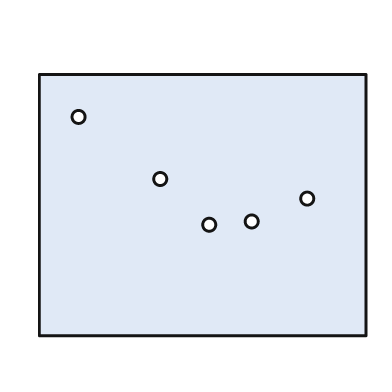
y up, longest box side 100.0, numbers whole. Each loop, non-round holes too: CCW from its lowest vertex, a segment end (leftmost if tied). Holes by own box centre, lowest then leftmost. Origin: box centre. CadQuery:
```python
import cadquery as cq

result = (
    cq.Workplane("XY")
    .moveTo(-50.0, -40.0)
    .lineTo(50.0, -40.0)
    .lineTo(50.0, 40.0)
    .lineTo(-50.0, 40.0)
    .close()
    .moveTo(2.0, -6.0)
    .circle(2.0)
    .moveTo(15.0, -5.0)
    .circle(2.0)
    .moveTo(32.0, 2.0)
    .circle(2.0)
    .moveTo(-13.0, 8.0)
    .circle(2.0)
    .moveTo(-38.0, 27.0)
    .circle(2.0)
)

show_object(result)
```